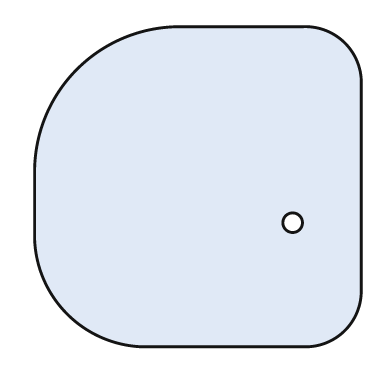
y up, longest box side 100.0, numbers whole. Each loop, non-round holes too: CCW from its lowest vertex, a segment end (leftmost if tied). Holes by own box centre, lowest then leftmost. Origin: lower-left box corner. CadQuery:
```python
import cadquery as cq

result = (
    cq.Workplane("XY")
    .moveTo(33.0, 0.0)
    .lineTo(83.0, 0.0)
    .threePointArc((95.0, 5.0), (100.0, 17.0))
    .lineTo(100.0, 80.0)
    .threePointArc((95.0, 93.0), (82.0, 98.0))
    .lineTo(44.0, 98.0)
    .threePointArc((13.0, 85.0), (0.0, 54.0))
    .lineTo(0.0, 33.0)
    .threePointArc((10.0, 10.0), (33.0, 0.0))
    .close()
    .moveTo(79.0, 38.0)
    .circle(3.0)
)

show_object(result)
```